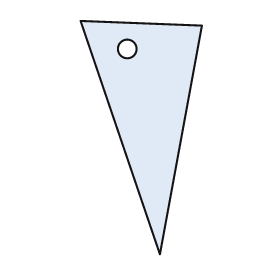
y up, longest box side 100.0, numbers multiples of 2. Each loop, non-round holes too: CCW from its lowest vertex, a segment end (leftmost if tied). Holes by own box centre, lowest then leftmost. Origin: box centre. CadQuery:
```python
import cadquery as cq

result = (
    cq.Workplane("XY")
    .moveTo(8.0, -50.0)
    .lineTo(26.0, 48.0)
    .lineTo(-26.0, 50.0)
    .close()
    .moveTo(-6.0, 38.0)
    .circle(4.0)
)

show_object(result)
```